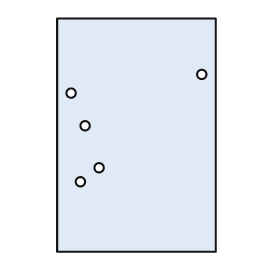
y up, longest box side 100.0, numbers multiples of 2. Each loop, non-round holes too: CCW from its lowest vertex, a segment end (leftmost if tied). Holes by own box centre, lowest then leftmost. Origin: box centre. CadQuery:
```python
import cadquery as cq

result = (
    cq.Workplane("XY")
    .moveTo(-34.0, -50.0)
    .lineTo(34.0, -50.0)
    .lineTo(34.0, 50.0)
    .lineTo(-34.0, 50.0)
    .close()
    .moveTo(-24.0, -20.0)
    .circle(2.0)
    .moveTo(-16.0, -14.0)
    .circle(2.0)
    .moveTo(-22.0, 4.0)
    .circle(2.0)
    .moveTo(-28.0, 18.0)
    .circle(2.0)
    .moveTo(28.0, 26.0)
    .circle(2.0)
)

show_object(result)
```